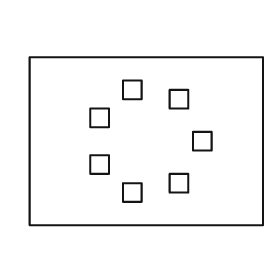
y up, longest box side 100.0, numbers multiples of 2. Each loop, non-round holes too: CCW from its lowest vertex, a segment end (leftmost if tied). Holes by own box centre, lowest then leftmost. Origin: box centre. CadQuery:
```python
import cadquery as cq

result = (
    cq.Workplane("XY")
    .moveTo(-50.0, -36.0)
    .lineTo(50.0, -36.0)
    .lineTo(50.0, 36.0)
    .lineTo(-50.0, 36.0)
    .close()
    .moveTo(-10.0, -26.0)
    .lineTo(-2.0, -26.0)
    .lineTo(-2.0, -18.0)
    .lineTo(-10.0, -18.0)
    .close()
    .moveTo(10.0, -22.0)
    .lineTo(18.0, -22.0)
    .lineTo(18.0, -14.0)
    .lineTo(10.0, -14.0)
    .close()
    .moveTo(-24.0, -14.0)
    .lineTo(-16.0, -14.0)
    .lineTo(-16.0, -6.0)
    .lineTo(-24.0, -6.0)
    .close()
    .moveTo(20.0, -4.0)
    .lineTo(28.0, -4.0)
    .lineTo(28.0, 4.0)
    .lineTo(20.0, 4.0)
    .close()
    .moveTo(-24.0, 6.0)
    .lineTo(-16.0, 6.0)
    .lineTo(-16.0, 14.0)
    .lineTo(-24.0, 14.0)
    .close()
    .moveTo(10.0, 14.0)
    .lineTo(18.0, 14.0)
    .lineTo(18.0, 22.0)
    .lineTo(10.0, 22.0)
    .close()
    .moveTo(-10.0, 18.0)
    .lineTo(-2.0, 18.0)
    .lineTo(-2.0, 26.0)
    .lineTo(-10.0, 26.0)
    .close()
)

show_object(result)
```